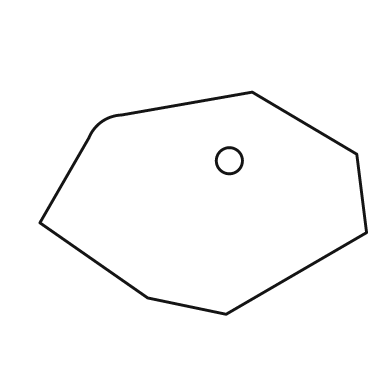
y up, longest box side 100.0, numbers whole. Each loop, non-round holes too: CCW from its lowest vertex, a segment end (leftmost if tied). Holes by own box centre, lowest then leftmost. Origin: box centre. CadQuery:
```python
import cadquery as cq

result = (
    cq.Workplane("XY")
    .moveTo(7.0, -34.0)
    .lineTo(50.0, -9.0)
    .lineTo(47.0, 15.0)
    .lineTo(15.0, 34.0)
    .lineTo(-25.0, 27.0)
    .threePointArc((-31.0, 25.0), (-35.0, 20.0))
    .lineTo(-50.0, -6.0)
    .lineTo(-17.0, -29.0)
    .close()
    .moveTo(8.0, 13.0)
    .circle(4.0)
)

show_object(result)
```